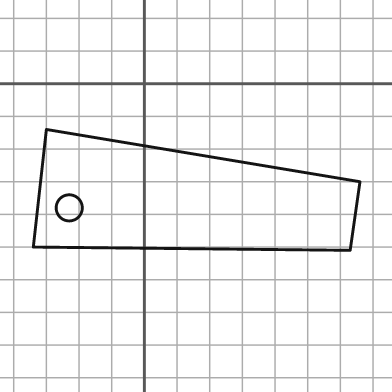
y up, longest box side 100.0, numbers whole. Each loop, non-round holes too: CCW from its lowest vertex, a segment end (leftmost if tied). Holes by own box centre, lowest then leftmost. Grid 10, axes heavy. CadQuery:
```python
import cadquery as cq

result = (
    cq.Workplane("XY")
    .moveTo(63.0, -51.0)
    .lineTo(66.0, -30.0)
    .lineTo(-30.0, -14.0)
    .lineTo(-34.0, -50.0)
    .close()
    .moveTo(-23.0, -38.0)
    .circle(4.0)
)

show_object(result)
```